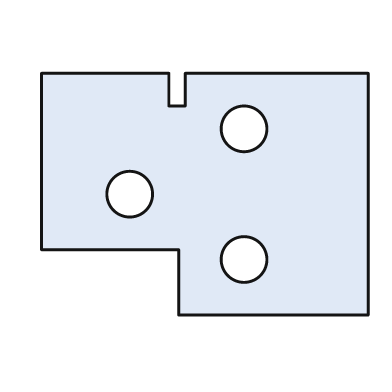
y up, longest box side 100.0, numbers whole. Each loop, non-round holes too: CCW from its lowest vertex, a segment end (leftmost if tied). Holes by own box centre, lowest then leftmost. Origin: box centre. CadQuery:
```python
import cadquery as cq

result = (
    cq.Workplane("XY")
    .moveTo(-8.0, -37.0)
    .lineTo(50.0, -37.0)
    .lineTo(50.0, 37.0)
    .lineTo(-6.0, 37.0)
    .lineTo(-6.0, 27.0)
    .lineTo(-11.0, 27.0)
    .lineTo(-11.0, 37.0)
    .lineTo(-50.0, 37.0)
    .lineTo(-50.0, -17.0)
    .lineTo(-8.0, -17.0)
    .close()
    .moveTo(12.0, -20.0)
    .circle(7.0)
    .moveTo(-23.0, 0.0)
    .circle(7.0)
    .moveTo(12.0, 20.0)
    .circle(7.0)
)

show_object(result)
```